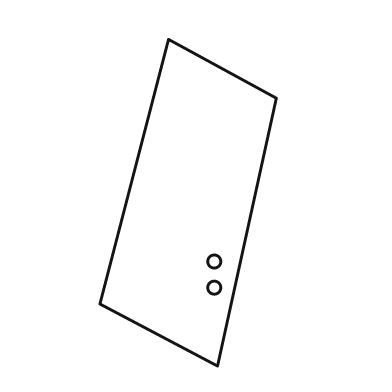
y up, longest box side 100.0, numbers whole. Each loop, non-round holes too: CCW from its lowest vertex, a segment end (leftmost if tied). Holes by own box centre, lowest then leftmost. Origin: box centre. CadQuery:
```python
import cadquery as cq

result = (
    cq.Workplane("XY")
    .moveTo(9.0, -50.0)
    .lineTo(27.0, 32.0)
    .lineTo(-6.0, 50.0)
    .lineTo(-27.0, -31.0)
    .close()
    .moveTo(8.0, -26.0)
    .circle(2.0)
    .moveTo(8.0, -18.0)
    .circle(2.0)
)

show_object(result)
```